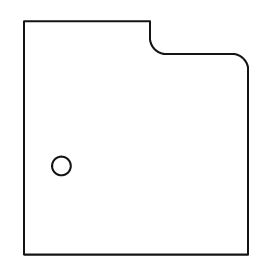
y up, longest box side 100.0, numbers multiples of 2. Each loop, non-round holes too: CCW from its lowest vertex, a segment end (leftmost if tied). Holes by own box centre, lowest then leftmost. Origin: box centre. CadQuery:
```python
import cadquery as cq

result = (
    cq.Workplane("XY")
    .moveTo(-48.0, -50.0)
    .lineTo(48.0, -50.0)
    .lineTo(48.0, 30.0)
    .threePointArc((46.0, 34.0), (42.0, 36.0))
    .lineTo(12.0, 36.0)
    .threePointArc((8.0, 38.0), (6.0, 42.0))
    .lineTo(6.0, 50.0)
    .lineTo(-48.0, 50.0)
    .close()
    .moveTo(-32.0, -12.0)
    .circle(4.0)
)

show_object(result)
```